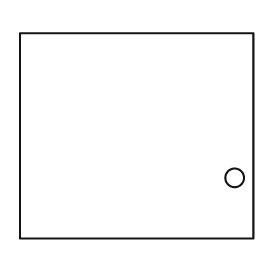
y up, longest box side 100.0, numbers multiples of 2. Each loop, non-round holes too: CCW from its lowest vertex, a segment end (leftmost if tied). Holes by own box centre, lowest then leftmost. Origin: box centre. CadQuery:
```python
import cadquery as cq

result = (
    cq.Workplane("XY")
    .moveTo(-50.0, -44.0)
    .lineTo(50.0, -44.0)
    .lineTo(50.0, 44.0)
    .lineTo(-50.0, 44.0)
    .close()
    .moveTo(42.0, -18.0)
    .circle(4.0)
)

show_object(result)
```